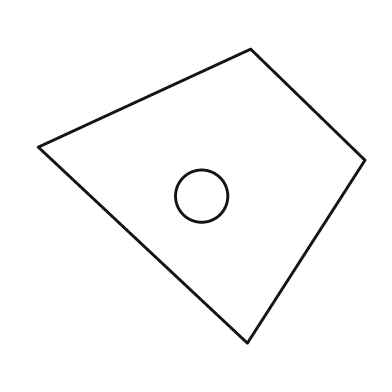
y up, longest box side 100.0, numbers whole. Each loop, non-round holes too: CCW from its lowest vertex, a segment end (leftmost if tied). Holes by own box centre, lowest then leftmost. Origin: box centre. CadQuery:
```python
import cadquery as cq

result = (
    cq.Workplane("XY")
    .moveTo(14.0, -45.0)
    .lineTo(50.0, 11.0)
    .lineTo(15.0, 45.0)
    .lineTo(-50.0, 15.0)
    .close()
    .moveTo(0.0, 0.0)
    .circle(8.0)
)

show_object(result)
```